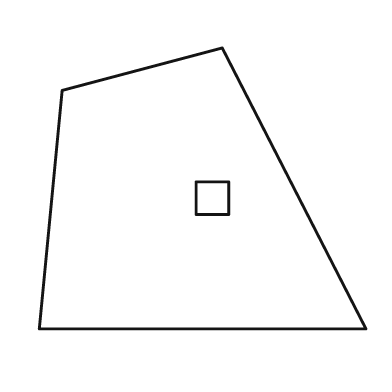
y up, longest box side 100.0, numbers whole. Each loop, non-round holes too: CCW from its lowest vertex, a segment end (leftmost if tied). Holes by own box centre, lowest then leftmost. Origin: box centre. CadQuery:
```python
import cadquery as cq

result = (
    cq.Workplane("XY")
    .moveTo(-50.0, -43.0)
    .lineTo(50.0, -43.0)
    .lineTo(6.0, 43.0)
    .lineTo(-43.0, 30.0)
    .close()
    .moveTo(-2.0, -8.0)
    .lineTo(8.0, -8.0)
    .lineTo(8.0, 2.0)
    .lineTo(-2.0, 2.0)
    .close()
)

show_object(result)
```